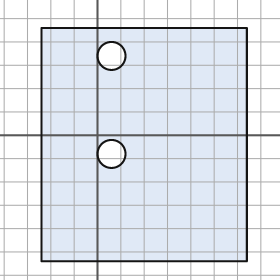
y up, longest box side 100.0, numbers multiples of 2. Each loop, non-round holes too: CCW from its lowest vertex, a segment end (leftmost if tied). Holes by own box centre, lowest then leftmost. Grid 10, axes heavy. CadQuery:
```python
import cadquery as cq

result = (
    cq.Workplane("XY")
    .moveTo(-24.0, -54.0)
    .lineTo(64.0, -54.0)
    .lineTo(64.0, 46.0)
    .lineTo(-24.0, 46.0)
    .close()
    .moveTo(6.0, -8.0)
    .circle(6.0)
    .moveTo(6.0, 34.0)
    .circle(6.0)
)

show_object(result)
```